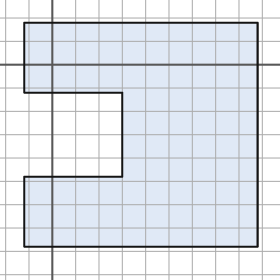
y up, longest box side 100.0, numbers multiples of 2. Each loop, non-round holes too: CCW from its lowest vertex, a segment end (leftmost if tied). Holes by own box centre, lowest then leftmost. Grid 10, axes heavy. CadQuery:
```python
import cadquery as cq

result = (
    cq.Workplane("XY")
    .moveTo(-12.0, -78.0)
    .lineTo(88.0, -78.0)
    .lineTo(88.0, 18.0)
    .lineTo(-12.0, 18.0)
    .lineTo(-12.0, -12.0)
    .lineTo(30.0, -12.0)
    .lineTo(30.0, -48.0)
    .lineTo(-12.0, -48.0)
    .close()
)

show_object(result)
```